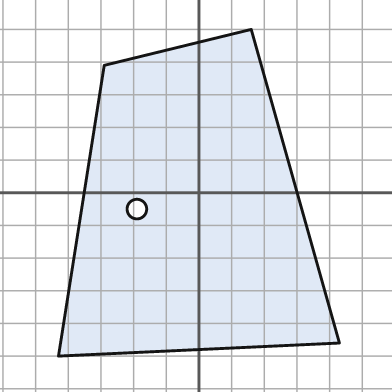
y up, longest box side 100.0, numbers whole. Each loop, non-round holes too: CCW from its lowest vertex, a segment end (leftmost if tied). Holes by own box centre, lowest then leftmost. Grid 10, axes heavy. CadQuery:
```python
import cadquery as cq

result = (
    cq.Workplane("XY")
    .moveTo(-43.0, -50.0)
    .lineTo(43.0, -46.0)
    .lineTo(16.0, 50.0)
    .lineTo(-29.0, 39.0)
    .close()
    .moveTo(-19.0, -5.0)
    .circle(3.0)
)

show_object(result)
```